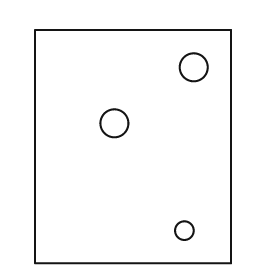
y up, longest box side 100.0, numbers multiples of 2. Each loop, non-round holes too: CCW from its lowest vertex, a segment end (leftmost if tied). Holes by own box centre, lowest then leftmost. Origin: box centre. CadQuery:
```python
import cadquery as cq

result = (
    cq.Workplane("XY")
    .moveTo(-42.0, -50.0)
    .lineTo(42.0, -50.0)
    .lineTo(42.0, 50.0)
    .lineTo(-42.0, 50.0)
    .close()
    .moveTo(22.0, -36.0)
    .circle(4.0)
    .moveTo(-8.0, 10.0)
    .circle(6.0)
    .moveTo(26.0, 34.0)
    .circle(6.0)
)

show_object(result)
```